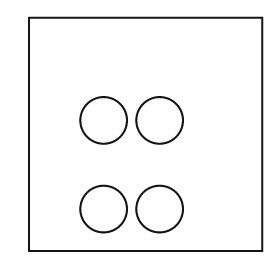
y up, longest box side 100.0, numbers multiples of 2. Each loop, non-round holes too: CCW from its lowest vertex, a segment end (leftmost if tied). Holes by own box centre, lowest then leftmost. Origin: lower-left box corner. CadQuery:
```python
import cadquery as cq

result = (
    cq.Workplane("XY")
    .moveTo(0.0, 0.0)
    .lineTo(100.0, 0.0)
    .lineTo(100.0, 100.0)
    .lineTo(0.0, 100.0)
    .close()
    .moveTo(32.0, 18.0)
    .circle(10.0)
    .moveTo(56.0, 18.0)
    .circle(10.0)
    .moveTo(32.0, 56.0)
    .circle(10.0)
    .moveTo(56.0, 56.0)
    .circle(10.0)
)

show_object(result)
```